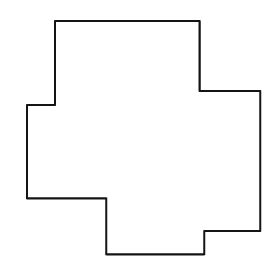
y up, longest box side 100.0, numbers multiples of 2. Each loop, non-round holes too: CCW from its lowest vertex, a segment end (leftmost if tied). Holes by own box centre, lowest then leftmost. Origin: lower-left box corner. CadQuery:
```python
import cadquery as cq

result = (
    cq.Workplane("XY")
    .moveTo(34.0, 0.0)
    .lineTo(76.0, 0.0)
    .lineTo(76.0, 10.0)
    .lineTo(100.0, 10.0)
    .lineTo(100.0, 70.0)
    .lineTo(74.0, 70.0)
    .lineTo(74.0, 100.0)
    .lineTo(12.0, 100.0)
    .lineTo(12.0, 64.0)
    .lineTo(0.0, 64.0)
    .lineTo(0.0, 24.0)
    .lineTo(34.0, 24.0)
    .close()
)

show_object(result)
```